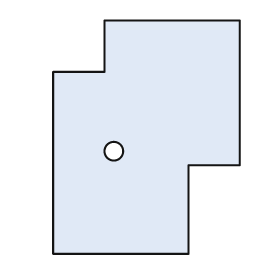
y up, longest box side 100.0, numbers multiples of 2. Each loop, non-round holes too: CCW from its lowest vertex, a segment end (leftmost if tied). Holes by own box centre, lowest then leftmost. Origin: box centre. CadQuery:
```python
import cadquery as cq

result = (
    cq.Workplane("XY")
    .moveTo(-40.0, -50.0)
    .lineTo(18.0, -50.0)
    .lineTo(18.0, -12.0)
    .lineTo(40.0, -12.0)
    .lineTo(40.0, 50.0)
    .lineTo(-18.0, 50.0)
    .lineTo(-18.0, 28.0)
    .lineTo(-40.0, 28.0)
    .close()
    .moveTo(-14.0, -6.0)
    .circle(4.0)
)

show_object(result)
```